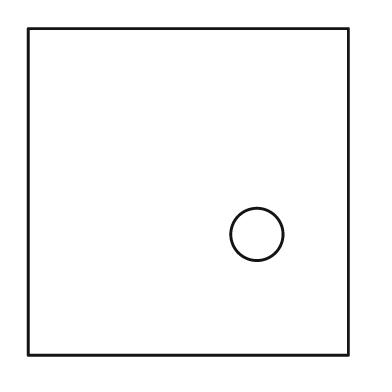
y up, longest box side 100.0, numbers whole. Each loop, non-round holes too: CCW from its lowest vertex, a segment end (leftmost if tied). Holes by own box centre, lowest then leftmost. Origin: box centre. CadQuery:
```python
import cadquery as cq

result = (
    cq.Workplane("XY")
    .moveTo(-49.0, -50.0)
    .lineTo(49.0, -50.0)
    .lineTo(49.0, 50.0)
    .lineTo(-49.0, 50.0)
    .close()
    .moveTo(21.0, -13.0)
    .circle(8.0)
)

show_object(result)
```